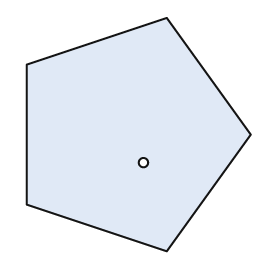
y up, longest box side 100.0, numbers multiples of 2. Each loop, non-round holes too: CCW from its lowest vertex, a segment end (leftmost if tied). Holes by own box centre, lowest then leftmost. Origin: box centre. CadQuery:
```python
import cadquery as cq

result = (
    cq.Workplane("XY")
    .moveTo(12.0, -50.0)
    .lineTo(48.0, 0.0)
    .lineTo(12.0, 50.0)
    .lineTo(-48.0, 30.0)
    .lineTo(-48.0, -30.0)
    .close()
    .moveTo(2.0, -12.0)
    .circle(2.0)
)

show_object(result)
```